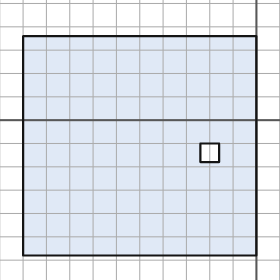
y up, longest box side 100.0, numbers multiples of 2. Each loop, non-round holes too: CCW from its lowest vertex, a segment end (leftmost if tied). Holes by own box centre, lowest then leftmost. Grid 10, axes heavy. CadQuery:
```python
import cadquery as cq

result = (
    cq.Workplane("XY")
    .moveTo(-100.0, -58.0)
    .lineTo(0.0, -58.0)
    .lineTo(0.0, 36.0)
    .lineTo(-100.0, 36.0)
    .close()
    .moveTo(-24.0, -18.0)
    .lineTo(-16.0, -18.0)
    .lineTo(-16.0, -10.0)
    .lineTo(-24.0, -10.0)
    .close()
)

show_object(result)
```